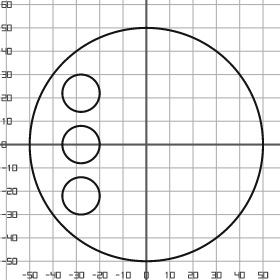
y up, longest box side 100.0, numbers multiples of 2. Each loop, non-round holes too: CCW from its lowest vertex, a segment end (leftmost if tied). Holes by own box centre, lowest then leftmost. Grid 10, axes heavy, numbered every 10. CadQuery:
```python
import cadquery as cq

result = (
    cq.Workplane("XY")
    .moveTo(0.0, 0.0)
    .circle(50.0)
    .moveTo(-28.0, -22.0)
    .circle(8.0)
    .moveTo(-28.0, 0.0)
    .circle(8.0)
    .moveTo(-28.0, 22.0)
    .circle(8.0)
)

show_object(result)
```